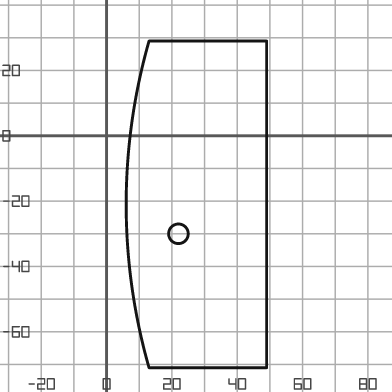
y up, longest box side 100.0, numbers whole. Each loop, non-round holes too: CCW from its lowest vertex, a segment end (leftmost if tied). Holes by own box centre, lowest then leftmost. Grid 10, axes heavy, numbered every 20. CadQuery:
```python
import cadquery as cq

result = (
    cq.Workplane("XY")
    .moveTo(13.0, -71.0)
    .lineTo(49.0, -71.0)
    .lineTo(49.0, 29.0)
    .lineTo(13.0, 29.0)
    .threePointArc((6.0, -21.0), (13.0, -71.0))
    .close()
    .moveTo(22.0, -30.0)
    .circle(3.0)
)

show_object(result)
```